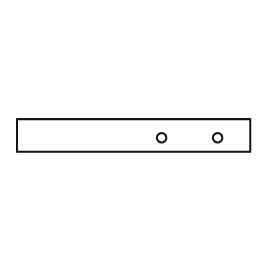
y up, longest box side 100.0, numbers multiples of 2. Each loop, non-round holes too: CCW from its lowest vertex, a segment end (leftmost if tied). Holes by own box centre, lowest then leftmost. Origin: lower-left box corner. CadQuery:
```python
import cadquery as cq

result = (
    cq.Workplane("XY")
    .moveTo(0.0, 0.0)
    .lineTo(100.0, 0.0)
    .lineTo(100.0, 14.0)
    .lineTo(0.0, 14.0)
    .close()
    .moveTo(62.0, 6.0)
    .circle(2.0)
    .moveTo(86.0, 6.0)
    .circle(2.0)
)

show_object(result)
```